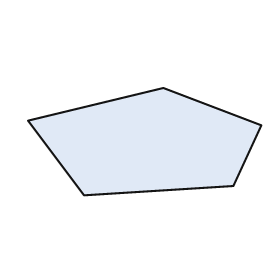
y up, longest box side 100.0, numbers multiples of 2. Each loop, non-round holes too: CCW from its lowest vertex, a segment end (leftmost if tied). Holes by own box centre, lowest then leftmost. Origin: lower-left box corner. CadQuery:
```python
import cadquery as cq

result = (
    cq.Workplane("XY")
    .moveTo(24.0, 0.0)
    .lineTo(88.0, 4.0)
    .lineTo(100.0, 30.0)
    .lineTo(58.0, 46.0)
    .lineTo(0.0, 32.0)
    .close()
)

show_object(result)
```